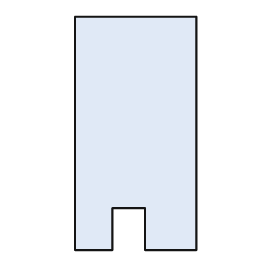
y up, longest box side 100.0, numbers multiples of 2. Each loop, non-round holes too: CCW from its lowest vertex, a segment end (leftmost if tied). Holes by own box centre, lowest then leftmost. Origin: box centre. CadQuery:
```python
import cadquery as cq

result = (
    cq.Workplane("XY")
    .moveTo(-26.0, -50.0)
    .lineTo(-10.0, -50.0)
    .lineTo(-10.0, -32.0)
    .lineTo(4.0, -32.0)
    .lineTo(4.0, -50.0)
    .lineTo(26.0, -50.0)
    .lineTo(26.0, 50.0)
    .lineTo(-26.0, 50.0)
    .close()
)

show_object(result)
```